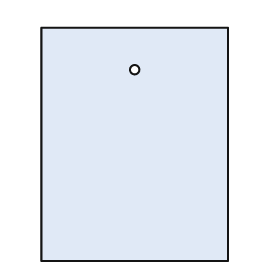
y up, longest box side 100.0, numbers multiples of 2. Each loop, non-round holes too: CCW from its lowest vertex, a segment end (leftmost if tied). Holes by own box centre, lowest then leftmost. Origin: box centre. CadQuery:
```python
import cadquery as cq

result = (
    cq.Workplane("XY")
    .moveTo(-40.0, -50.0)
    .lineTo(40.0, -50.0)
    .lineTo(40.0, 50.0)
    .lineTo(-40.0, 50.0)
    .close()
    .moveTo(0.0, 32.0)
    .circle(2.0)
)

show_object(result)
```